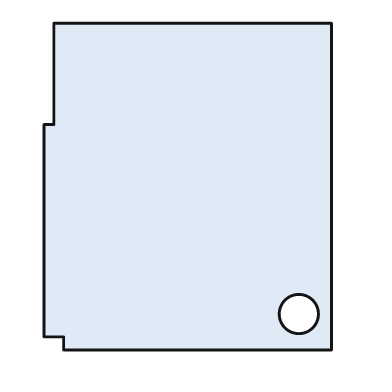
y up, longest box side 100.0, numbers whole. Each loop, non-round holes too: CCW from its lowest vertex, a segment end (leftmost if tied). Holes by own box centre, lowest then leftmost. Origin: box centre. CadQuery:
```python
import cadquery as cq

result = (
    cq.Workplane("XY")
    .moveTo(-38.0, -50.0)
    .lineTo(44.0, -50.0)
    .lineTo(44.0, 50.0)
    .lineTo(-41.0, 50.0)
    .lineTo(-41.0, 19.0)
    .lineTo(-44.0, 19.0)
    .lineTo(-44.0, -46.0)
    .lineTo(-38.0, -46.0)
    .close()
    .moveTo(34.0, -39.0)
    .circle(6.0)
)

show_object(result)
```